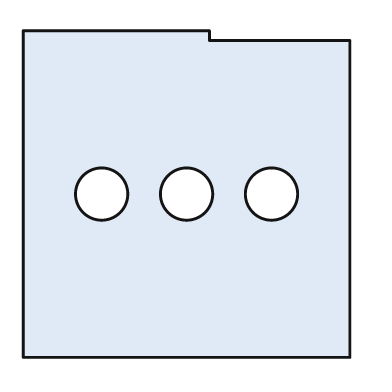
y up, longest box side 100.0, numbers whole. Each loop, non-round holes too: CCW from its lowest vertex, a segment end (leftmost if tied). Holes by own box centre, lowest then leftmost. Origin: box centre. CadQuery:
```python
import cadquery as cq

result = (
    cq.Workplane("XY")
    .moveTo(-50.0, -50.0)
    .lineTo(50.0, -50.0)
    .lineTo(50.0, 47.0)
    .lineTo(7.0, 47.0)
    .lineTo(7.0, 50.0)
    .lineTo(-50.0, 50.0)
    .close()
    .moveTo(-26.0, 0.0)
    .circle(8.0)
    .moveTo(0.0, 0.0)
    .circle(8.0)
    .moveTo(26.0, 0.0)
    .circle(8.0)
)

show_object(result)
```